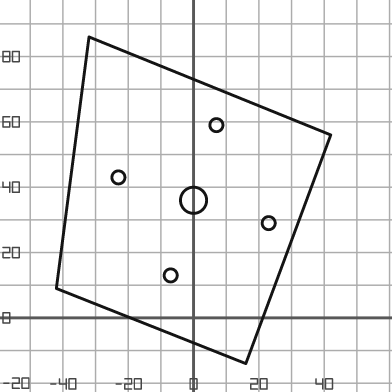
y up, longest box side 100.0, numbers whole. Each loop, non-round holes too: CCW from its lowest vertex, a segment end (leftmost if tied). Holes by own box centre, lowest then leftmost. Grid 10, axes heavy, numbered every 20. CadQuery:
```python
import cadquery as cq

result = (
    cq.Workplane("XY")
    .moveTo(16.0, -14.0)
    .lineTo(42.0, 56.0)
    .lineTo(-32.0, 86.0)
    .lineTo(-42.0, 9.0)
    .close()
    .moveTo(-7.0, 13.0)
    .circle(2.0)
    .moveTo(23.0, 29.0)
    .circle(2.0)
    .moveTo(0.0, 36.0)
    .circle(4.0)
    .moveTo(-23.0, 43.0)
    .circle(2.0)
    .moveTo(7.0, 59.0)
    .circle(2.0)
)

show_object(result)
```